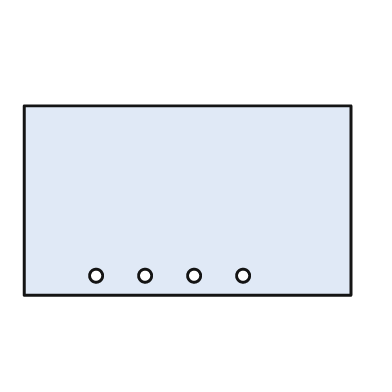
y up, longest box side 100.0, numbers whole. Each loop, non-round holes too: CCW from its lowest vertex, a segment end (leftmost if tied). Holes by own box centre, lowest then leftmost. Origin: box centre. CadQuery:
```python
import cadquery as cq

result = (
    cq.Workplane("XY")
    .moveTo(-50.0, -29.0)
    .lineTo(50.0, -29.0)
    .lineTo(50.0, 29.0)
    .lineTo(-50.0, 29.0)
    .close()
    .moveTo(-28.0, -23.0)
    .circle(2.0)
    .moveTo(-13.0, -23.0)
    .circle(2.0)
    .moveTo(2.0, -23.0)
    .circle(2.0)
    .moveTo(17.0, -23.0)
    .circle(2.0)
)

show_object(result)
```